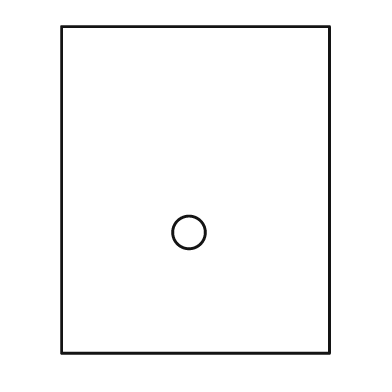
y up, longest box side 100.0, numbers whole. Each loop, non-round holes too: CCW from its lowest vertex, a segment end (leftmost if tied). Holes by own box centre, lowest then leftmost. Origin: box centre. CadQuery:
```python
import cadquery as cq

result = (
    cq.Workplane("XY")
    .moveTo(-41.0, -50.0)
    .lineTo(41.0, -50.0)
    .lineTo(41.0, 50.0)
    .lineTo(-41.0, 50.0)
    .close()
    .moveTo(-2.0, -13.0)
    .circle(5.0)
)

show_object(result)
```